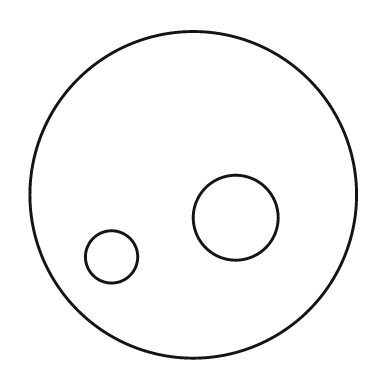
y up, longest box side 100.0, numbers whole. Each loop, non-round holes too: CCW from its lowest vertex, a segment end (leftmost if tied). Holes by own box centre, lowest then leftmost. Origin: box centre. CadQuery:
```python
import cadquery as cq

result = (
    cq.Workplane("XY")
    .moveTo(0.0, 0.0)
    .circle(50.0)
    .moveTo(-25.0, -19.0)
    .circle(8.0)
    .moveTo(13.0, -7.0)
    .circle(13.0)
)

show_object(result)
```